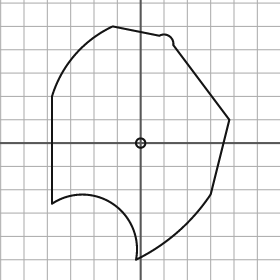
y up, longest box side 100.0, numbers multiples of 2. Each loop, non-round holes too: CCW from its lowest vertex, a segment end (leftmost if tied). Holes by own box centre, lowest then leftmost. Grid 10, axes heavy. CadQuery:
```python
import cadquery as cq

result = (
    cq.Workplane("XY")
    .moveTo(-2.0, -50.0)
    .threePointArc((16.0, -38.0), (30.0, -22.0))
    .lineTo(38.0, 10.0)
    .lineTo(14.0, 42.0)
    .threePointArc((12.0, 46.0), (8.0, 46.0))
    .lineTo(-12.0, 50.0)
    .threePointArc((-28.0, 38.0), (-38.0, 20.0))
    .lineTo(-38.0, -26.0)
    .threePointArc((-12.0, -26.0), (-2.0, -50.0))
    .close()
    .moveTo(0.0, 0.0)
    .circle(2.0)
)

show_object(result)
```